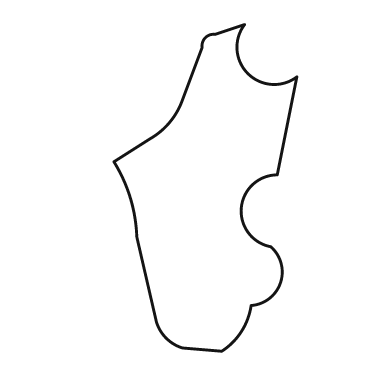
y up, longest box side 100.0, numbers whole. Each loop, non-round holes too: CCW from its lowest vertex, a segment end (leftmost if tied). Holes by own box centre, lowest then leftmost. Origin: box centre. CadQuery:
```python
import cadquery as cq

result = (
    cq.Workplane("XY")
    .moveTo(5.0, -50.0)
    .threePointArc((11.0, -44.0), (14.0, -36.0))
    .threePointArc((23.0, -29.0), (20.0, -18.0))
    .threePointArc((11.0, -6.0), (22.0, 4.0))
    .lineTo(28.0, 34.0)
    .threePointArc((13.0, 35.0), (12.0, 50.0))
    .lineTo(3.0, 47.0)
    .threePointArc((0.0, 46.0), (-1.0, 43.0))
    .lineTo(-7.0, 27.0)
    .threePointArc((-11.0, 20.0), (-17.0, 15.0))
    .lineTo(-28.0, 8.0)
    .threePointArc((-23.0, -3.0), (-21.0, -15.0))
    .lineTo(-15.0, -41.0)
    .threePointArc((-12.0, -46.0), (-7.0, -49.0))
    .close()
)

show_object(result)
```